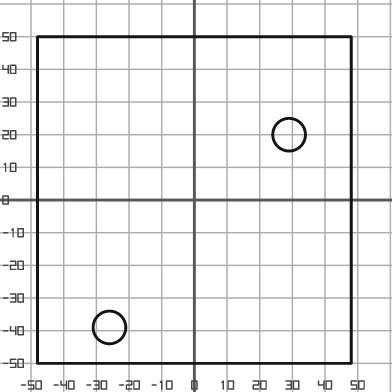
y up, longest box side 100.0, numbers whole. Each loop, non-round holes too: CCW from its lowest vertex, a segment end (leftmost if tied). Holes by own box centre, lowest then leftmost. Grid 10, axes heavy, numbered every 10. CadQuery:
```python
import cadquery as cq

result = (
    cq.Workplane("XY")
    .moveTo(-48.0, -50.0)
    .lineTo(48.0, -50.0)
    .lineTo(48.0, 50.0)
    .lineTo(-48.0, 50.0)
    .close()
    .moveTo(-26.0, -39.0)
    .circle(5.0)
    .moveTo(29.0, 20.0)
    .circle(5.0)
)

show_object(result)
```